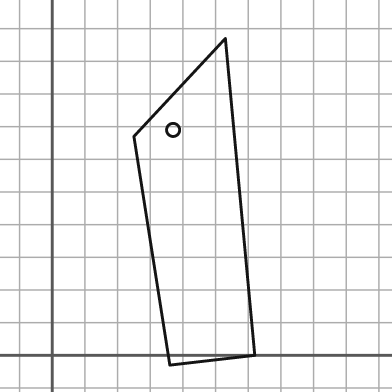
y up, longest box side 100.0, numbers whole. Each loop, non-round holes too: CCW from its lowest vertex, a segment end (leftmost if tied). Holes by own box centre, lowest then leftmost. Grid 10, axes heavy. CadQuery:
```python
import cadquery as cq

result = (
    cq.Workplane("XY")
    .moveTo(36.0, -3.0)
    .lineTo(62.0, 0.0)
    .lineTo(53.0, 97.0)
    .lineTo(25.0, 67.0)
    .close()
    .moveTo(37.0, 69.0)
    .circle(2.0)
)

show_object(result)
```